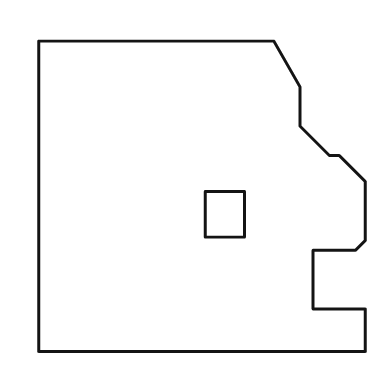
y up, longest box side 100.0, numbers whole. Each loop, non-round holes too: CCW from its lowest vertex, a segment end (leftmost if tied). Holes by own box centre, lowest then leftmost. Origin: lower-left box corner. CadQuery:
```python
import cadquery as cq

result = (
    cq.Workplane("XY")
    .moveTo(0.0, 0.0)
    .lineTo(100.0, 0.0)
    .lineTo(100.0, 13.0)
    .lineTo(84.0, 13.0)
    .lineTo(84.0, 31.0)
    .lineTo(97.0, 31.0)
    .lineTo(100.0, 34.0)
    .lineTo(100.0, 52.0)
    .lineTo(92.0, 60.0)
    .lineTo(89.0, 60.0)
    .lineTo(80.0, 69.0)
    .lineTo(80.0, 81.0)
    .lineTo(72.0, 95.0)
    .lineTo(0.0, 95.0)
    .close()
    .moveTo(51.0, 35.0)
    .lineTo(63.0, 35.0)
    .lineTo(63.0, 49.0)
    .lineTo(51.0, 49.0)
    .close()
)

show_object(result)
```